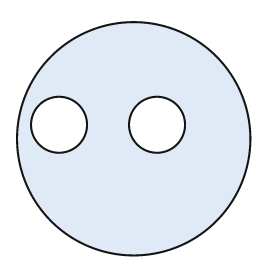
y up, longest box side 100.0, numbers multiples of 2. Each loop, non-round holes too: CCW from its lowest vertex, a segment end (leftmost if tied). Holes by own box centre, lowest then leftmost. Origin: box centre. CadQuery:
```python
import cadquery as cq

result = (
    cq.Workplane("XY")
    .moveTo(0.0, 0.0)
    .circle(50.0)
    .moveTo(-32.0, 6.0)
    .circle(12.0)
    .moveTo(10.0, 6.0)
    .circle(12.0)
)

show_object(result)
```